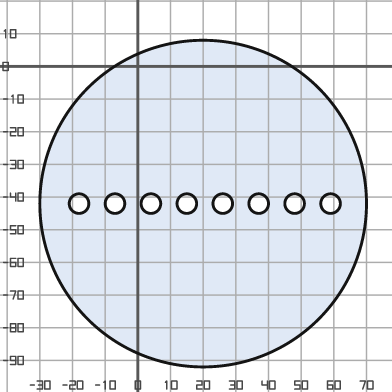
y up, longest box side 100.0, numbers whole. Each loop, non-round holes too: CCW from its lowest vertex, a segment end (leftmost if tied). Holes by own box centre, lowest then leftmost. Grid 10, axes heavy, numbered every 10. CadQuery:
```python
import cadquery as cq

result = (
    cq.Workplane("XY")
    .moveTo(20.0, -42.0)
    .circle(50.0)
    .moveTo(-18.0, -42.0)
    .circle(3.0)
    .moveTo(-7.0, -42.0)
    .circle(3.0)
    .moveTo(4.0, -42.0)
    .circle(3.0)
    .moveTo(15.0, -42.0)
    .circle(3.0)
    .moveTo(26.0, -42.0)
    .circle(3.0)
    .moveTo(37.0, -42.0)
    .circle(3.0)
    .moveTo(48.0, -42.0)
    .circle(3.0)
    .moveTo(59.0, -42.0)
    .circle(3.0)
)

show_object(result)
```